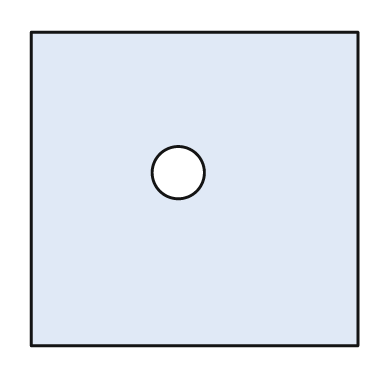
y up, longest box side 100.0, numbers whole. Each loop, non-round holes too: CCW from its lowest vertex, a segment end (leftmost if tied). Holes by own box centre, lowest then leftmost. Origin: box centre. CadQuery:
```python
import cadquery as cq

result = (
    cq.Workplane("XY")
    .moveTo(-50.0, -48.0)
    .lineTo(50.0, -48.0)
    .lineTo(50.0, 48.0)
    .lineTo(-50.0, 48.0)
    .close()
    .moveTo(-5.0, 5.0)
    .circle(8.0)
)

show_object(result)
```